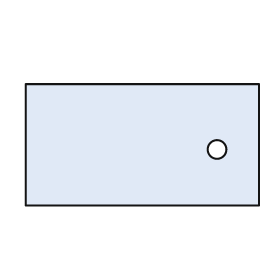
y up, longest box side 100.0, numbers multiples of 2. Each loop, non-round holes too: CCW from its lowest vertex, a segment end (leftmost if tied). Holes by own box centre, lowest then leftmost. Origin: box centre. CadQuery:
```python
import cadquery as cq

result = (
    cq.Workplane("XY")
    .moveTo(-50.0, -26.0)
    .lineTo(50.0, -26.0)
    .lineTo(50.0, 26.0)
    .lineTo(-50.0, 26.0)
    .close()
    .moveTo(32.0, -2.0)
    .circle(4.0)
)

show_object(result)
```